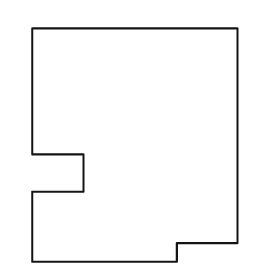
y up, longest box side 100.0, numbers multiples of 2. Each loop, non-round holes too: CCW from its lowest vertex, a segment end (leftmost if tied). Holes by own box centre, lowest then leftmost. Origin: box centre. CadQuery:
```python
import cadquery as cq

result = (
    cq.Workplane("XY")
    .moveTo(-44.0, -50.0)
    .lineTo(18.0, -50.0)
    .lineTo(18.0, -42.0)
    .lineTo(44.0, -42.0)
    .lineTo(44.0, 50.0)
    .lineTo(-44.0, 50.0)
    .lineTo(-44.0, -4.0)
    .lineTo(-22.0, -4.0)
    .lineTo(-22.0, -20.0)
    .lineTo(-44.0, -20.0)
    .close()
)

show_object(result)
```